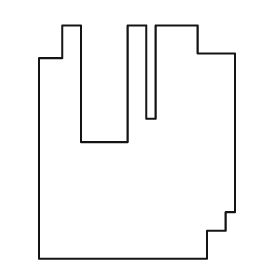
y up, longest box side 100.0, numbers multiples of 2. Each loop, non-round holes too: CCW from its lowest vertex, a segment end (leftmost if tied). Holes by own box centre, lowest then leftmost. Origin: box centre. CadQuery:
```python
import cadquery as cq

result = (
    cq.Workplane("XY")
    .moveTo(-42.0, -50.0)
    .lineTo(30.0, -50.0)
    .lineTo(30.0, -38.0)
    .lineTo(38.0, -38.0)
    .lineTo(38.0, -30.0)
    .lineTo(42.0, -30.0)
    .lineTo(42.0, 38.0)
    .lineTo(26.0, 38.0)
    .lineTo(26.0, 50.0)
    .lineTo(8.0, 50.0)
    .lineTo(8.0, 10.0)
    .lineTo(4.0, 10.0)
    .lineTo(4.0, 50.0)
    .lineTo(-4.0, 50.0)
    .lineTo(-4.0, 0.0)
    .lineTo(-24.0, 0.0)
    .lineTo(-24.0, 50.0)
    .lineTo(-32.0, 50.0)
    .lineTo(-32.0, 36.0)
    .lineTo(-42.0, 36.0)
    .close()
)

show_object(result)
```